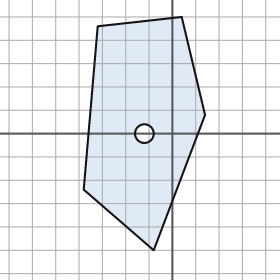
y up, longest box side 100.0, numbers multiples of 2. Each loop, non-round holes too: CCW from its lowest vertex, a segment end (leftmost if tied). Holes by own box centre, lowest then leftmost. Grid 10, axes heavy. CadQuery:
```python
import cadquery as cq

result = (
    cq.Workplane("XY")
    .moveTo(-8.0, -50.0)
    .lineTo(14.0, 8.0)
    .lineTo(4.0, 50.0)
    .lineTo(-32.0, 46.0)
    .lineTo(-38.0, -24.0)
    .close()
    .moveTo(-12.0, 0.0)
    .circle(4.0)
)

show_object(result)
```